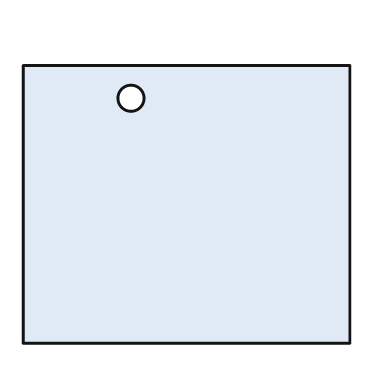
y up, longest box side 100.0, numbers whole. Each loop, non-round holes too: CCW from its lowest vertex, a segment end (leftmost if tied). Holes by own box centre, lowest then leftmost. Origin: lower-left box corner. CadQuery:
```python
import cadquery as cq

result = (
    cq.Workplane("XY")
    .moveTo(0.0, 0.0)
    .lineTo(100.0, 0.0)
    .lineTo(100.0, 85.0)
    .lineTo(0.0, 85.0)
    .close()
    .moveTo(33.0, 75.0)
    .circle(4.0)
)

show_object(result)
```